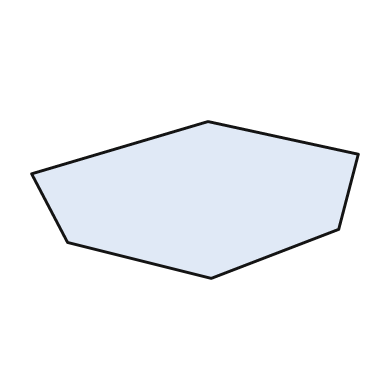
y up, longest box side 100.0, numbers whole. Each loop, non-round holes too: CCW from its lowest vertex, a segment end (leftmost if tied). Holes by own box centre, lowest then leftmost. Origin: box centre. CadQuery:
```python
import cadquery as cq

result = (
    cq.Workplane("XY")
    .moveTo(5.0, -24.0)
    .lineTo(44.0, -9.0)
    .lineTo(50.0, 14.0)
    .lineTo(4.0, 24.0)
    .lineTo(-50.0, 8.0)
    .lineTo(-39.0, -13.0)
    .close()
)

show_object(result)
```